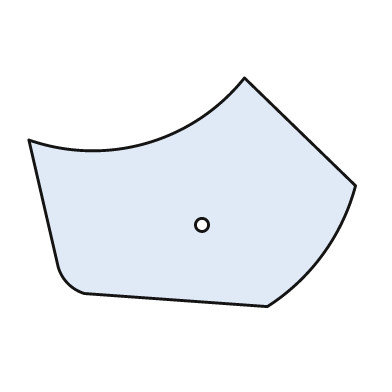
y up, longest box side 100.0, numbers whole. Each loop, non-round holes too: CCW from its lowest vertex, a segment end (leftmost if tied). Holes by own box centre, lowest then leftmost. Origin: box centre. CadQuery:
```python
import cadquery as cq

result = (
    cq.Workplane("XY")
    .moveTo(23.0, -35.0)
    .threePointArc((40.0, -19.0), (50.0, 2.0))
    .lineTo(16.0, 35.0)
    .threePointArc((-14.0, 15.0), (-50.0, 16.0))
    .lineTo(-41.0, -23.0)
    .threePointArc((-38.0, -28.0), (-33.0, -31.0))
    .close()
    .moveTo(3.0, -10.0)
    .circle(2.0)
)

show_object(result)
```